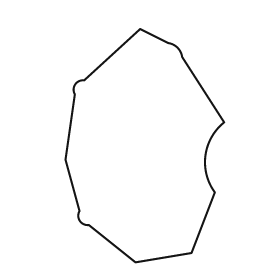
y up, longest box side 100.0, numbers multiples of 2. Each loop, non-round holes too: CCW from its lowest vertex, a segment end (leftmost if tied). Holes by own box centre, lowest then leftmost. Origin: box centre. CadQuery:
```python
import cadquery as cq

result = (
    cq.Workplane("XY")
    .moveTo(-4.0, -50.0)
    .lineTo(20.0, -46.0)
    .lineTo(30.0, -20.0)
    .threePointArc((26.0, -4.0), (34.0, 10.0))
    .lineTo(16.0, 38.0)
    .threePointArc((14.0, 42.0), (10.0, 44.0))
    .lineTo(-2.0, 50.0)
    .lineTo(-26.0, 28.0)
    .threePointArc((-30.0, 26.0), (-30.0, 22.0))
    .lineTo(-34.0, -6.0)
    .lineTo(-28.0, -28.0)
    .threePointArc((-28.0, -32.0), (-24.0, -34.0))
    .close()
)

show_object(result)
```